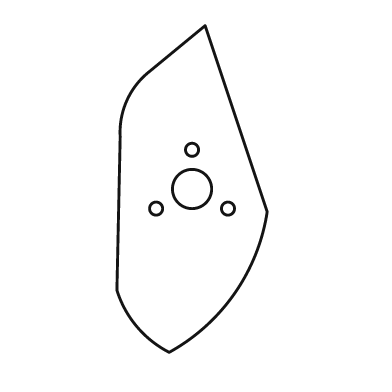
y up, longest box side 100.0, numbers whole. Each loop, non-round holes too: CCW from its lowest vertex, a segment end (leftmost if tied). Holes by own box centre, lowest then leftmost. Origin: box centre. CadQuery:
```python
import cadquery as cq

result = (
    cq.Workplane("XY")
    .moveTo(-7.0, -50.0)
    .threePointArc((13.0, -32.0), (23.0, -7.0))
    .lineTo(4.0, 50.0)
    .lineTo(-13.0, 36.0)
    .threePointArc((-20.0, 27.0), (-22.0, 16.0))
    .lineTo(-23.0, -31.0)
    .threePointArc((-17.0, -42.0), (-7.0, -50.0))
    .close()
    .moveTo(-11.0, -6.0)
    .circle(2.0)
    .moveTo(11.0, -6.0)
    .circle(2.0)
    .moveTo(0.0, 0.0)
    .circle(6.0)
    .moveTo(0.0, 12.0)
    .circle(2.0)
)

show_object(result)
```